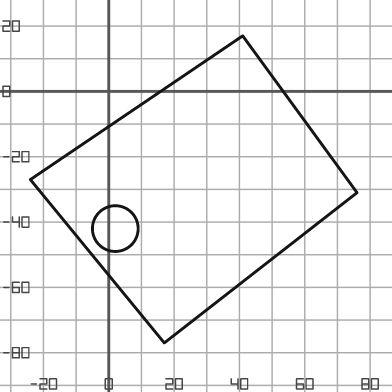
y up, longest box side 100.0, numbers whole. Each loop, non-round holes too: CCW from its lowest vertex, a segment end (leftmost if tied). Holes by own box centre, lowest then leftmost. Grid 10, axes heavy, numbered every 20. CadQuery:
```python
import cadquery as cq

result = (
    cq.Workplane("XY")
    .moveTo(17.0, -77.0)
    .lineTo(76.0, -31.0)
    .lineTo(41.0, 17.0)
    .lineTo(-24.0, -27.0)
    .close()
    .moveTo(2.0, -42.0)
    .circle(7.0)
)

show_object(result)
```